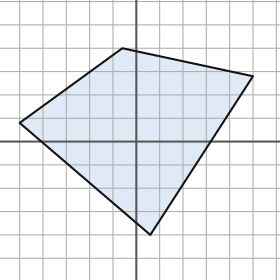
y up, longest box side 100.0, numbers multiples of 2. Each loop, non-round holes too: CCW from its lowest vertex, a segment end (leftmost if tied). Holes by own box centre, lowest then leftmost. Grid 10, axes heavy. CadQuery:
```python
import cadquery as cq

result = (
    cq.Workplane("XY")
    .moveTo(6.0, -40.0)
    .lineTo(50.0, 28.0)
    .lineTo(-6.0, 40.0)
    .lineTo(-50.0, 8.0)
    .close()
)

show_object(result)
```